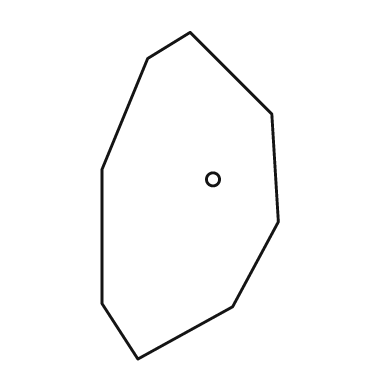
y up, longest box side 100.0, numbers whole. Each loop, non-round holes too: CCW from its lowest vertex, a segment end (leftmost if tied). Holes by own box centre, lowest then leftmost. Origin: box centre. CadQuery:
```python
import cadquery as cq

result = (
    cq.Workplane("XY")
    .moveTo(-16.0, -50.0)
    .lineTo(13.0, -34.0)
    .lineTo(27.0, -8.0)
    .lineTo(25.0, 25.0)
    .lineTo(0.0, 50.0)
    .lineTo(-13.0, 42.0)
    .lineTo(-27.0, 8.0)
    .lineTo(-27.0, -33.0)
    .close()
    .moveTo(7.0, 5.0)
    .circle(2.0)
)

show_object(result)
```